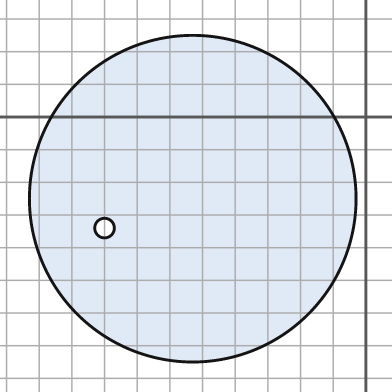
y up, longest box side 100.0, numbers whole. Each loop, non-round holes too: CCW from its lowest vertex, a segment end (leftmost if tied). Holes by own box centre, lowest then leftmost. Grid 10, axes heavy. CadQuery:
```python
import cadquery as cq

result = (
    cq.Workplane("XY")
    .moveTo(-53.0, -25.0)
    .circle(50.0)
    .moveTo(-80.0, -34.0)
    .circle(3.0)
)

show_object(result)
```